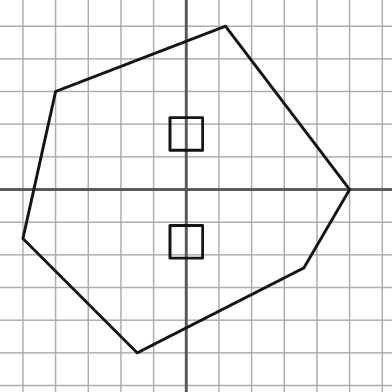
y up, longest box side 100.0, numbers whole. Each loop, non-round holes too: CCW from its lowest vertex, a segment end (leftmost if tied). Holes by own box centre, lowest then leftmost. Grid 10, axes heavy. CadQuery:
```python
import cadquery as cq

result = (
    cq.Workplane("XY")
    .moveTo(-15.0, -50.0)
    .lineTo(36.0, -24.0)
    .lineTo(50.0, 0.0)
    .lineTo(12.0, 50.0)
    .lineTo(-40.0, 30.0)
    .lineTo(-50.0, -15.0)
    .close()
    .moveTo(-5.0, -21.0)
    .lineTo(5.0, -21.0)
    .lineTo(5.0, -11.0)
    .lineTo(-5.0, -11.0)
    .close()
    .moveTo(-5.0, 12.0)
    .lineTo(5.0, 12.0)
    .lineTo(5.0, 22.0)
    .lineTo(-5.0, 22.0)
    .close()
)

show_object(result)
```